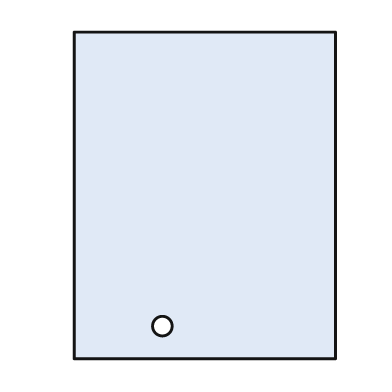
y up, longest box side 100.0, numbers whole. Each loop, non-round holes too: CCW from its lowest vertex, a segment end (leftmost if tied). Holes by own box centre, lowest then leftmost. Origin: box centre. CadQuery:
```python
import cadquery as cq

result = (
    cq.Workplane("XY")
    .moveTo(-40.0, -50.0)
    .lineTo(40.0, -50.0)
    .lineTo(40.0, 50.0)
    .lineTo(-40.0, 50.0)
    .close()
    .moveTo(-13.0, -40.0)
    .circle(3.0)
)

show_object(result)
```